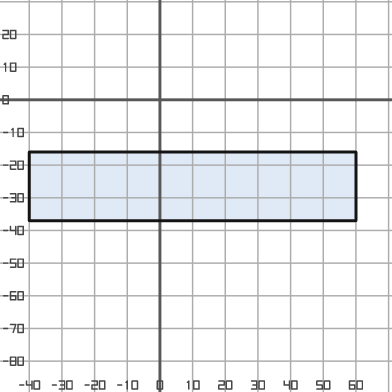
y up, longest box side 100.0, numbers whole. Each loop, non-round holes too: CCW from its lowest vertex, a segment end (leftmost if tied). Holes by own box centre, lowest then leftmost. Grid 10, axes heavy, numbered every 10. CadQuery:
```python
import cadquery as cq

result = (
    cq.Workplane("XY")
    .moveTo(-40.0, -37.0)
    .lineTo(60.0, -37.0)
    .lineTo(60.0, -16.0)
    .lineTo(-40.0, -16.0)
    .close()
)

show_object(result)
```